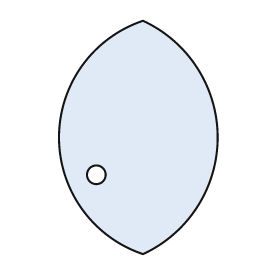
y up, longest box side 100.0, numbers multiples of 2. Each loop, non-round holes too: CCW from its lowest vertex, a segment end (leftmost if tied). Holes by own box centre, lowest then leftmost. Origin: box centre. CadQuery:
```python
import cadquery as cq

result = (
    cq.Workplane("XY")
    .moveTo(2.0, -50.0)
    .threePointArc((34.0, 0.0), (2.0, 50.0))
    .threePointArc((-34.0, 0.0), (2.0, -50.0))
    .close()
    .moveTo(-18.0, -16.0)
    .circle(4.0)
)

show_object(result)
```